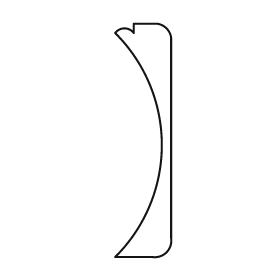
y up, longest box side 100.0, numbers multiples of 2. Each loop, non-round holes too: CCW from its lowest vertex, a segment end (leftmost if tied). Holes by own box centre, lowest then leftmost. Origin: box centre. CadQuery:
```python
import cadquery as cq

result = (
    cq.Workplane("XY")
    .moveTo(-12.0, -50.0)
    .lineTo(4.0, -50.0)
    .threePointArc((10.0, -48.0), (12.0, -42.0))
    .lineTo(12.0, 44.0)
    .threePointArc((10.0, 48.0), (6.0, 50.0))
    .lineTo(-4.0, 50.0)
    .lineTo(-4.0, 46.0)
    .threePointArc((-8.0, 48.0), (-12.0, 46.0))
    .threePointArc((8.0, -2.0), (-12.0, -50.0))
    .close()
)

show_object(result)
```